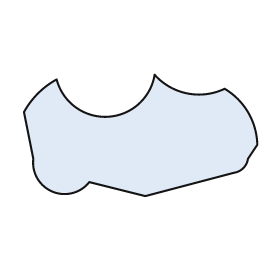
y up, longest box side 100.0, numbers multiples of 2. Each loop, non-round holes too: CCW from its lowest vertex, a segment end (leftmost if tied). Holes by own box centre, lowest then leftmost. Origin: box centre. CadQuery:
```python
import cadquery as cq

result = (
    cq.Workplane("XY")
    .moveTo(2.0, -26.0)
    .lineTo(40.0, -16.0)
    .threePointArc((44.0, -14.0), (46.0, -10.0))
    .lineTo(50.0, -4.0)
    .threePointArc((46.0, 10.0), (36.0, 20.0))
    .threePointArc((20.0, 18.0), (6.0, 26.0))
    .threePointArc((-14.0, 8.0), (-36.0, 24.0))
    .threePointArc((-44.0, 18.0), (-50.0, 10.0))
    .lineTo(-46.0, -10.0)
    .threePointArc((-38.0, -24.0), (-22.0, -20.0))
    .close()
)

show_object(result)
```